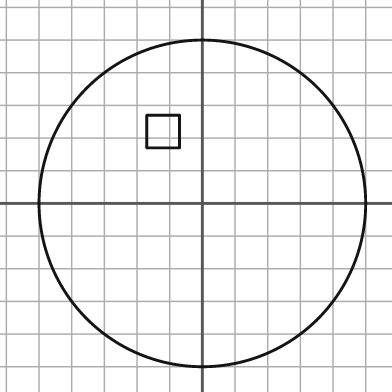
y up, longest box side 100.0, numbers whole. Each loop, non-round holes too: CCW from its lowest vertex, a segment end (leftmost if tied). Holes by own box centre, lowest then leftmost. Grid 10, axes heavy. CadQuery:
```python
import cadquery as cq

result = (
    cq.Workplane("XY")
    .moveTo(0.0, 0.0)
    .circle(50.0)
    .moveTo(-17.0, 17.0)
    .lineTo(-7.0, 17.0)
    .lineTo(-7.0, 27.0)
    .lineTo(-17.0, 27.0)
    .close()
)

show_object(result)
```